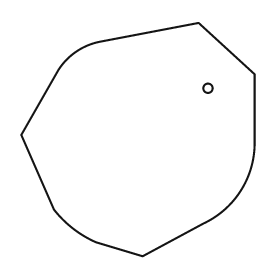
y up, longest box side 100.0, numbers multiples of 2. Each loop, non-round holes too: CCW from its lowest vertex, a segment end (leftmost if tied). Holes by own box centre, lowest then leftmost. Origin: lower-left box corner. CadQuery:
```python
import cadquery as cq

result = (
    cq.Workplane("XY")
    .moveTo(52.0, 0.0)
    .lineTo(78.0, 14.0)
    .threePointArc((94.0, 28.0), (100.0, 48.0))
    .lineTo(100.0, 78.0)
    .lineTo(76.0, 100.0)
    .lineTo(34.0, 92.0)
    .threePointArc((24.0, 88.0), (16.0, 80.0))
    .lineTo(0.0, 52.0)
    .lineTo(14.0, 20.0)
    .threePointArc((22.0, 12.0), (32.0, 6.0))
    .close()
    .moveTo(80.0, 72.0)
    .circle(2.0)
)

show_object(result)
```